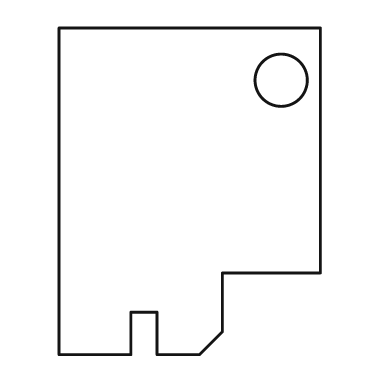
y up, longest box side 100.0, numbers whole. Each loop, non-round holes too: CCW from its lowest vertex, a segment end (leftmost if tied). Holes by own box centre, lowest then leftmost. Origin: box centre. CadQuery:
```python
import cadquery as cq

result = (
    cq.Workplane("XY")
    .moveTo(-40.0, -50.0)
    .lineTo(-18.0, -50.0)
    .lineTo(-18.0, -37.0)
    .lineTo(-10.0, -37.0)
    .lineTo(-10.0, -50.0)
    .lineTo(3.0, -50.0)
    .lineTo(10.0, -43.0)
    .lineTo(10.0, -25.0)
    .lineTo(40.0, -25.0)
    .lineTo(40.0, 50.0)
    .lineTo(-40.0, 50.0)
    .close()
    .moveTo(28.0, 34.0)
    .circle(8.0)
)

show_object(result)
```